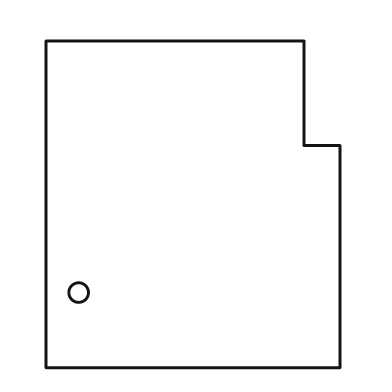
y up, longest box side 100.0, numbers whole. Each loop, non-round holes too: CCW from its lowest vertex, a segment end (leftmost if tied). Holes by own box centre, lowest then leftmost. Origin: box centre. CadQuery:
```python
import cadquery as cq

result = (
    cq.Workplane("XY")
    .moveTo(-45.0, -50.0)
    .lineTo(45.0, -50.0)
    .lineTo(45.0, 18.0)
    .lineTo(34.0, 18.0)
    .lineTo(34.0, 50.0)
    .lineTo(-45.0, 50.0)
    .close()
    .moveTo(-35.0, -27.0)
    .circle(3.0)
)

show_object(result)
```